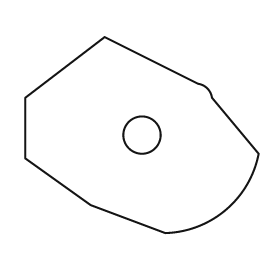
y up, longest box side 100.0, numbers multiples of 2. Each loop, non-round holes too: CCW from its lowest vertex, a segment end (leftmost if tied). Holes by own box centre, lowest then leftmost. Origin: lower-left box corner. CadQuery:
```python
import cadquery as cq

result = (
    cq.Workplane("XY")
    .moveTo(60.0, 0.0)
    .threePointArc((86.0, 10.0), (100.0, 34.0))
    .lineTo(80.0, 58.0)
    .threePointArc((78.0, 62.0), (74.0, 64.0))
    .lineTo(34.0, 84.0)
    .lineTo(0.0, 58.0)
    .lineTo(0.0, 32.0)
    .lineTo(28.0, 12.0)
    .close()
    .moveTo(50.0, 42.0)
    .circle(8.0)
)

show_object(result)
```